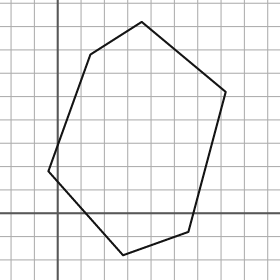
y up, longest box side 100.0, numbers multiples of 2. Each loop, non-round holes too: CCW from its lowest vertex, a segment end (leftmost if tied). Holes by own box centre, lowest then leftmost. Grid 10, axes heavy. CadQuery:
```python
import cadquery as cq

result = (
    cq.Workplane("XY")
    .moveTo(28.0, -18.0)
    .lineTo(56.0, -8.0)
    .lineTo(72.0, 52.0)
    .lineTo(36.0, 82.0)
    .lineTo(14.0, 68.0)
    .lineTo(-4.0, 18.0)
    .close()
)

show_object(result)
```